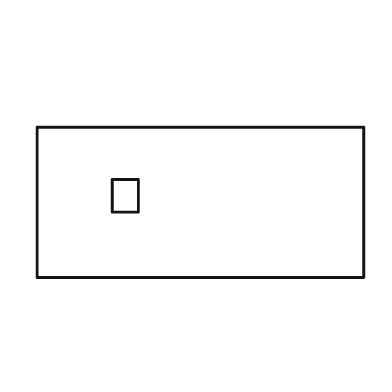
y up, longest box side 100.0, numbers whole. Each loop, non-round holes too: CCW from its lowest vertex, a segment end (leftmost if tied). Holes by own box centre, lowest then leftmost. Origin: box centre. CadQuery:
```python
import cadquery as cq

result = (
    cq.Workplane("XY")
    .moveTo(-50.0, -23.0)
    .lineTo(50.0, -23.0)
    .lineTo(50.0, 23.0)
    .lineTo(-50.0, 23.0)
    .close()
    .moveTo(-27.0, -3.0)
    .lineTo(-19.0, -3.0)
    .lineTo(-19.0, 7.0)
    .lineTo(-27.0, 7.0)
    .close()
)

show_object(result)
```